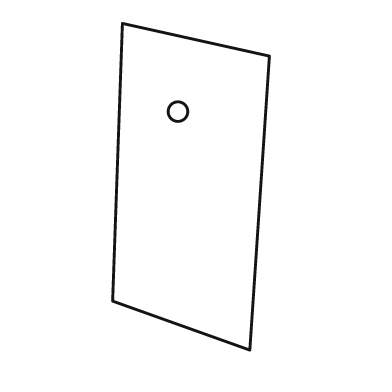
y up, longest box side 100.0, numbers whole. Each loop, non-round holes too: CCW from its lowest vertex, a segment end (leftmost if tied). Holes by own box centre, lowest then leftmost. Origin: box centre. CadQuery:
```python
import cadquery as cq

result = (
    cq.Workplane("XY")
    .moveTo(18.0, -50.0)
    .lineTo(24.0, 40.0)
    .lineTo(-21.0, 50.0)
    .lineTo(-24.0, -35.0)
    .close()
    .moveTo(-4.0, 23.0)
    .circle(3.0)
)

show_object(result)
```